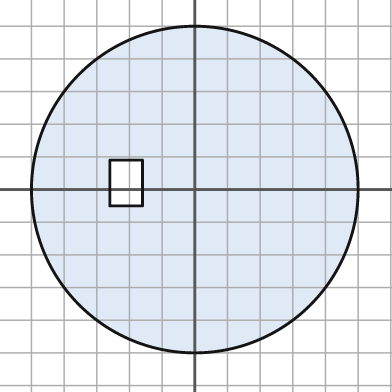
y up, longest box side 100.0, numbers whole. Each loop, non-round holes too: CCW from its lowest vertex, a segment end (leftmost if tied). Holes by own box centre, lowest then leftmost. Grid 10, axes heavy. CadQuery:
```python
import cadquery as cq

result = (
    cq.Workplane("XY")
    .moveTo(0.0, 0.0)
    .circle(50.0)
    .moveTo(-26.0, -5.0)
    .lineTo(-16.0, -5.0)
    .lineTo(-16.0, 9.0)
    .lineTo(-26.0, 9.0)
    .close()
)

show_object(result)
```